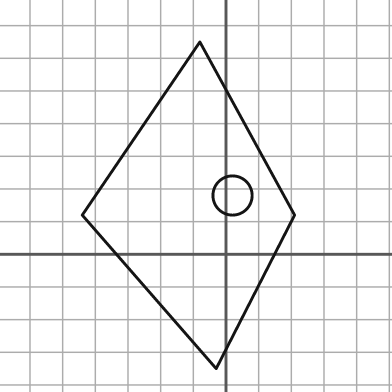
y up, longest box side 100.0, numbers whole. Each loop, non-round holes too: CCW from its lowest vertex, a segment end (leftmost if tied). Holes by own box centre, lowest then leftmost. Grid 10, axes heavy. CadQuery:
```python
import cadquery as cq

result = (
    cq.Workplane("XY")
    .moveTo(-3.0, -35.0)
    .lineTo(21.0, 12.0)
    .lineTo(-8.0, 65.0)
    .lineTo(-44.0, 12.0)
    .close()
    .moveTo(2.0, 18.0)
    .circle(6.0)
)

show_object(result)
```